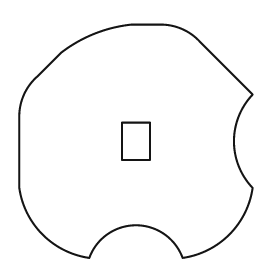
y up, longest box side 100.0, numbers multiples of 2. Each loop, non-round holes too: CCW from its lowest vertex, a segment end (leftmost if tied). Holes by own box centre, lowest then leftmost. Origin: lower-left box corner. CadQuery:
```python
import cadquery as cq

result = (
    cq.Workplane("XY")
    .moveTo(30.0, 0.0)
    .threePointArc((50.0, 14.0), (70.0, 0.0))
    .threePointArc((90.0, 10.0), (100.0, 30.0))
    .threePointArc((92.0, 50.0), (100.0, 70.0))
    .lineTo(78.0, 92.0)
    .threePointArc((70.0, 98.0), (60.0, 100.0))
    .lineTo(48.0, 100.0)
    .threePointArc((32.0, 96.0), (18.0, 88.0))
    .lineTo(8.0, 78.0)
    .threePointArc((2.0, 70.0), (0.0, 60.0))
    .lineTo(0.0, 30.0)
    .threePointArc((10.0, 10.0), (30.0, 0.0))
    .close()
    .moveTo(44.0, 42.0)
    .lineTo(56.0, 42.0)
    .lineTo(56.0, 58.0)
    .lineTo(44.0, 58.0)
    .close()
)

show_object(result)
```